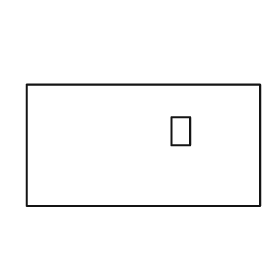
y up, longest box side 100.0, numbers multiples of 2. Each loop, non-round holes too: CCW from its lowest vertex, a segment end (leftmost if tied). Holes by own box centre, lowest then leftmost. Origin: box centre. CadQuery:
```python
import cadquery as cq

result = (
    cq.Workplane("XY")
    .moveTo(-50.0, -26.0)
    .lineTo(50.0, -26.0)
    .lineTo(50.0, 26.0)
    .lineTo(-50.0, 26.0)
    .close()
    .moveTo(12.0, 0.0)
    .lineTo(20.0, 0.0)
    .lineTo(20.0, 12.0)
    .lineTo(12.0, 12.0)
    .close()
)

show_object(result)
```